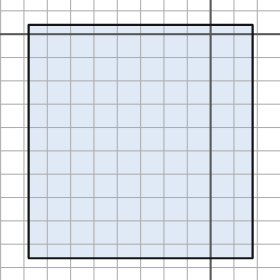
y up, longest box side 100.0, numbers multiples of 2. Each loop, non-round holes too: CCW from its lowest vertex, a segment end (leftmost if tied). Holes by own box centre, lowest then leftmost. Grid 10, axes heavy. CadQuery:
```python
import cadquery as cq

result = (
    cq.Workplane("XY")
    .moveTo(-78.0, -96.0)
    .lineTo(18.0, -96.0)
    .lineTo(18.0, 4.0)
    .lineTo(-78.0, 4.0)
    .close()
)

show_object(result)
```